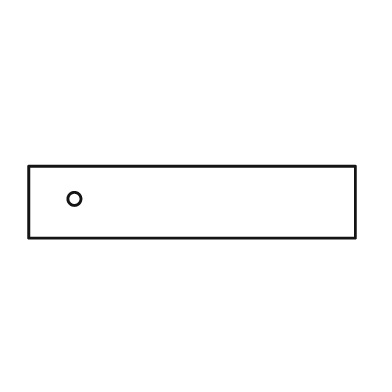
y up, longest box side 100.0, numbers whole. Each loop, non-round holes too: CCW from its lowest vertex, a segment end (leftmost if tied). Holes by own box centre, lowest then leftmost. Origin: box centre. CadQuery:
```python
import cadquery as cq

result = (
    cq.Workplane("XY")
    .moveTo(-50.0, -11.0)
    .lineTo(50.0, -11.0)
    .lineTo(50.0, 11.0)
    .lineTo(-50.0, 11.0)
    .close()
    .moveTo(-36.0, 1.0)
    .circle(2.0)
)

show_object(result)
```